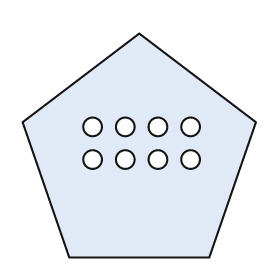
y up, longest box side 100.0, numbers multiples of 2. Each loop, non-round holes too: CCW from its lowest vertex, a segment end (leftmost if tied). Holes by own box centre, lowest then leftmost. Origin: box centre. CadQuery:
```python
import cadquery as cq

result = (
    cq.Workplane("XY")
    .moveTo(-30.0, -48.0)
    .lineTo(30.0, -48.0)
    .lineTo(50.0, 10.0)
    .lineTo(0.0, 48.0)
    .lineTo(-50.0, 10.0)
    .close()
    .moveTo(-20.0, -6.0)
    .circle(4.0)
    .moveTo(-6.0, -6.0)
    .circle(4.0)
    .moveTo(8.0, -6.0)
    .circle(4.0)
    .moveTo(22.0, -6.0)
    .circle(4.0)
    .moveTo(-20.0, 8.0)
    .circle(4.0)
    .moveTo(-6.0, 8.0)
    .circle(4.0)
    .moveTo(8.0, 8.0)
    .circle(4.0)
    .moveTo(22.0, 8.0)
    .circle(4.0)
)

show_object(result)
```